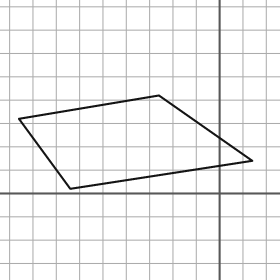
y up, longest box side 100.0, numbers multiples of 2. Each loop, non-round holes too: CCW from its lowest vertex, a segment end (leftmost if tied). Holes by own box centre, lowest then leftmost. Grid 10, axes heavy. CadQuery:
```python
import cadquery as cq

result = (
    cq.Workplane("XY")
    .moveTo(-64.0, 2.0)
    .lineTo(14.0, 14.0)
    .lineTo(-26.0, 42.0)
    .lineTo(-86.0, 32.0)
    .close()
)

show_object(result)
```